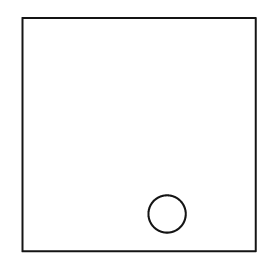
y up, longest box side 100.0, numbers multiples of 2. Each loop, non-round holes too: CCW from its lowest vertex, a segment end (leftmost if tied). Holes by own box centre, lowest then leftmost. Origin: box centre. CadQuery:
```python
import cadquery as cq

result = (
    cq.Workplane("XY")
    .moveTo(-50.0, -50.0)
    .lineTo(50.0, -50.0)
    .lineTo(50.0, 50.0)
    .lineTo(-50.0, 50.0)
    .close()
    .moveTo(12.0, -34.0)
    .circle(8.0)
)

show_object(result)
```